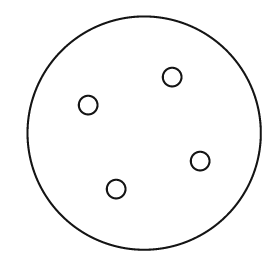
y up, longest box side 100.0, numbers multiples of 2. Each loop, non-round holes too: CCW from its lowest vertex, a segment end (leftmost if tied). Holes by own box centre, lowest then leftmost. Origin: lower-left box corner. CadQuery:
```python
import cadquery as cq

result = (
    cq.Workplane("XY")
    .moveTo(50.0, 50.0)
    .circle(50.0)
    .moveTo(38.0, 26.0)
    .circle(4.0)
    .moveTo(74.0, 38.0)
    .circle(4.0)
    .moveTo(26.0, 62.0)
    .circle(4.0)
    .moveTo(62.0, 74.0)
    .circle(4.0)
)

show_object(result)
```